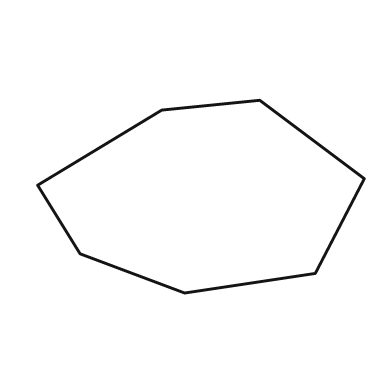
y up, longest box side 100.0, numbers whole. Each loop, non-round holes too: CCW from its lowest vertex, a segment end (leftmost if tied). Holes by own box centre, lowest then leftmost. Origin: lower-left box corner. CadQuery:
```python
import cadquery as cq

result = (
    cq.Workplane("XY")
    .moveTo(45.0, 0.0)
    .lineTo(85.0, 6.0)
    .lineTo(100.0, 35.0)
    .lineTo(68.0, 59.0)
    .lineTo(38.0, 56.0)
    .lineTo(0.0, 33.0)
    .lineTo(13.0, 12.0)
    .close()
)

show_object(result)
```